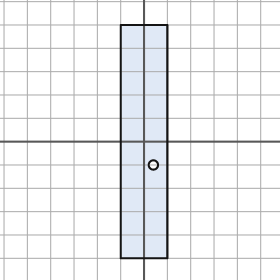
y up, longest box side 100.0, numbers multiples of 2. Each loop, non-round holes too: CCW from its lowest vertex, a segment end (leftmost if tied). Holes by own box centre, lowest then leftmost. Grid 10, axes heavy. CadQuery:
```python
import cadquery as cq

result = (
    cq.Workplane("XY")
    .moveTo(-10.0, -50.0)
    .lineTo(10.0, -50.0)
    .lineTo(10.0, 50.0)
    .lineTo(-10.0, 50.0)
    .close()
    .moveTo(4.0, -10.0)
    .circle(2.0)
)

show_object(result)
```